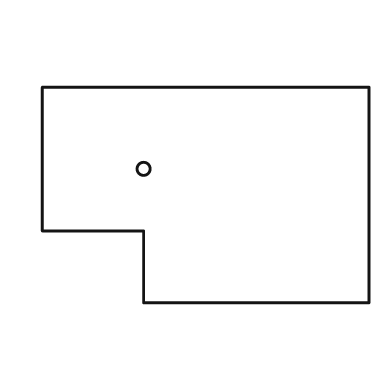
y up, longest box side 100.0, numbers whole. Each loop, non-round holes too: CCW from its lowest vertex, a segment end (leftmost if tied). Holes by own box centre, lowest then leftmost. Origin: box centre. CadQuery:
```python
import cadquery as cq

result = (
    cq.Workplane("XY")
    .moveTo(-19.0, -33.0)
    .lineTo(50.0, -33.0)
    .lineTo(50.0, 33.0)
    .lineTo(-50.0, 33.0)
    .lineTo(-50.0, -11.0)
    .lineTo(-19.0, -11.0)
    .close()
    .moveTo(-19.0, 8.0)
    .circle(2.0)
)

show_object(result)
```